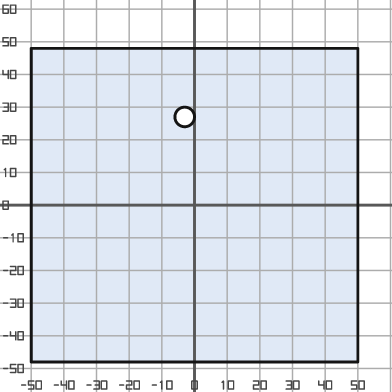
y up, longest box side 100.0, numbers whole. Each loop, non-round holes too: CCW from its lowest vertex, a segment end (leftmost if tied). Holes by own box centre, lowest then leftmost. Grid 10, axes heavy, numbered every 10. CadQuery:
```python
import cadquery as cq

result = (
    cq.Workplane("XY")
    .moveTo(-50.0, -48.0)
    .lineTo(50.0, -48.0)
    .lineTo(50.0, 48.0)
    .lineTo(-50.0, 48.0)
    .close()
    .moveTo(-3.0, 27.0)
    .circle(3.0)
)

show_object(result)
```